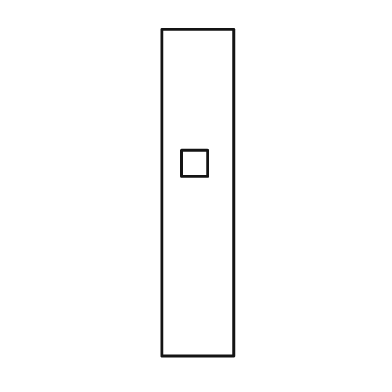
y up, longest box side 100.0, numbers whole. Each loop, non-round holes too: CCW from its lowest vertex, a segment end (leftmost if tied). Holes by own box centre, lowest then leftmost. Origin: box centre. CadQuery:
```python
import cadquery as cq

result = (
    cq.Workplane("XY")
    .moveTo(-11.0, -50.0)
    .lineTo(11.0, -50.0)
    .lineTo(11.0, 50.0)
    .lineTo(-11.0, 50.0)
    .close()
    .moveTo(-5.0, 5.0)
    .lineTo(3.0, 5.0)
    .lineTo(3.0, 13.0)
    .lineTo(-5.0, 13.0)
    .close()
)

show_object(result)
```